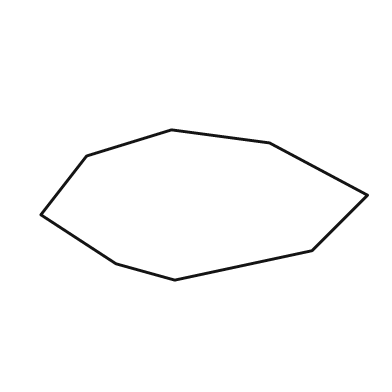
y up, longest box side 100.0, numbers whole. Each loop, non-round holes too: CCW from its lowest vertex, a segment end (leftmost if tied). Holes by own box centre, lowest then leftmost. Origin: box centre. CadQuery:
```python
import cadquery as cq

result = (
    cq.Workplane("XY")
    .moveTo(-9.0, -23.0)
    .lineTo(33.0, -14.0)
    .lineTo(50.0, 3.0)
    .lineTo(20.0, 19.0)
    .lineTo(-10.0, 23.0)
    .lineTo(-36.0, 15.0)
    .lineTo(-50.0, -3.0)
    .lineTo(-27.0, -18.0)
    .close()
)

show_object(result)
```